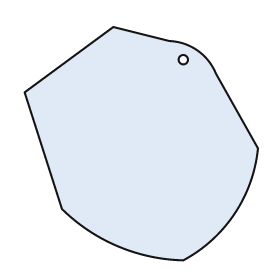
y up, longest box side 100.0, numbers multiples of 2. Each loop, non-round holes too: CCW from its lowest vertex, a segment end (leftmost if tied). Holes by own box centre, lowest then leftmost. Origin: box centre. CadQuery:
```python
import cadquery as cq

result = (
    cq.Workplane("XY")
    .moveTo(18.0, -50.0)
    .threePointArc((40.0, -30.0), (50.0, -2.0))
    .lineTo(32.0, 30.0)
    .threePointArc((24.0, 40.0), (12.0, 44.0))
    .lineTo(-12.0, 50.0)
    .lineTo(-50.0, 22.0)
    .lineTo(-34.0, -28.0)
    .threePointArc((-10.0, -44.0), (18.0, -50.0))
    .close()
    .moveTo(18.0, 36.0)
    .circle(2.0)
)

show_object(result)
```